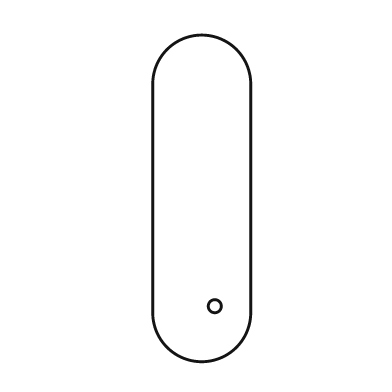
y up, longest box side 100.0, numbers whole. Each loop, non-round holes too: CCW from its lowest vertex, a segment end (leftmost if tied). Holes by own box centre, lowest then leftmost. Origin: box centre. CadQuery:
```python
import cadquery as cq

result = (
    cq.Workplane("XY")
    .moveTo(-15.0, -35.0)
    .threePointArc((0.0, -50.0), (15.0, -35.0))
    .lineTo(15.0, 35.0)
    .threePointArc((0.0, 50.0), (-15.0, 35.0))
    .close()
    .moveTo(4.0, -33.0)
    .circle(2.0)
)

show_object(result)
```